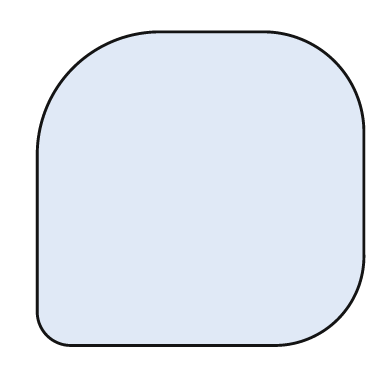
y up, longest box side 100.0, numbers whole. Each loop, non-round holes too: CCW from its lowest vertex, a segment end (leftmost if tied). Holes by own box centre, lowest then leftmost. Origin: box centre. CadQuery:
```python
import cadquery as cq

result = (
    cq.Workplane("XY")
    .moveTo(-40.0, -48.0)
    .lineTo(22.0, -48.0)
    .threePointArc((42.0, -40.0), (50.0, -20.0))
    .lineTo(50.0, 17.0)
    .threePointArc((41.0, 39.0), (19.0, 48.0))
    .lineTo(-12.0, 48.0)
    .threePointArc((-39.0, 37.0), (-50.0, 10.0))
    .lineTo(-50.0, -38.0)
    .threePointArc((-47.0, -45.0), (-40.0, -48.0))
    .close()
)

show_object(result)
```